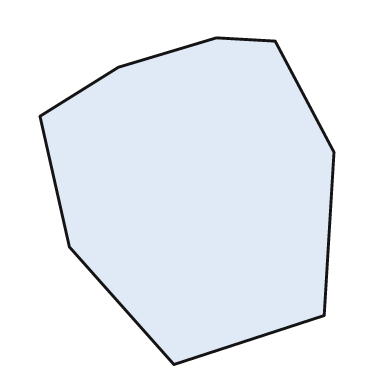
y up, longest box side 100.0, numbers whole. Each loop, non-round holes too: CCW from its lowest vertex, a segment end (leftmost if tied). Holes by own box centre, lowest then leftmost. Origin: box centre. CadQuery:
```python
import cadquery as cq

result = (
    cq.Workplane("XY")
    .moveTo(-4.0, -50.0)
    .lineTo(42.0, -35.0)
    .lineTo(45.0, 15.0)
    .lineTo(27.0, 49.0)
    .lineTo(9.0, 50.0)
    .lineTo(-21.0, 41.0)
    .lineTo(-45.0, 26.0)
    .lineTo(-36.0, -14.0)
    .close()
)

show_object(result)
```